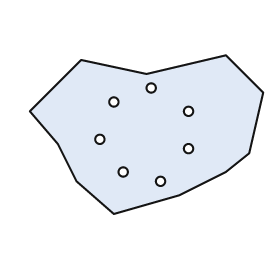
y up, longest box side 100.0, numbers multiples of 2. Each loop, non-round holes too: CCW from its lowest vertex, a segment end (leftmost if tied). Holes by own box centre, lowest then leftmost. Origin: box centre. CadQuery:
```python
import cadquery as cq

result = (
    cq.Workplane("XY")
    .moveTo(-14.0, -34.0)
    .lineTo(14.0, -26.0)
    .lineTo(34.0, -16.0)
    .lineTo(44.0, -8.0)
    .lineTo(50.0, 18.0)
    .lineTo(34.0, 34.0)
    .lineTo(0.0, 26.0)
    .lineTo(-28.0, 32.0)
    .lineTo(-50.0, 10.0)
    .lineTo(-38.0, -4.0)
    .lineTo(-30.0, -20.0)
    .close()
    .moveTo(6.0, -20.0)
    .circle(2.0)
    .moveTo(-10.0, -16.0)
    .circle(2.0)
    .moveTo(18.0, -6.0)
    .circle(2.0)
    .moveTo(-20.0, -2.0)
    .circle(2.0)
    .moveTo(18.0, 10.0)
    .circle(2.0)
    .moveTo(-14.0, 14.0)
    .circle(2.0)
    .moveTo(2.0, 20.0)
    .circle(2.0)
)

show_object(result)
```